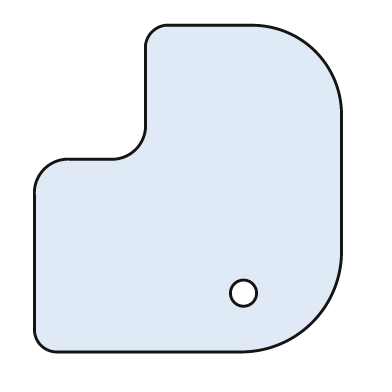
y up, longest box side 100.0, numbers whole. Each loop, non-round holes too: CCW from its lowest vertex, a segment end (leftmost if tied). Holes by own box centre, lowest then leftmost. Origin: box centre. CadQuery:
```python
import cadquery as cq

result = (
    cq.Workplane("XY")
    .moveTo(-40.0, -50.0)
    .lineTo(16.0, -50.0)
    .threePointArc((38.0, -41.0), (47.0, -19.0))
    .lineTo(47.0, 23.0)
    .threePointArc((39.0, 42.0), (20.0, 50.0))
    .lineTo(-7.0, 50.0)
    .threePointArc((-11.0, 48.0), (-13.0, 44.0))
    .lineTo(-13.0, 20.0)
    .threePointArc((-16.0, 12.0), (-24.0, 9.0))
    .lineTo(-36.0, 9.0)
    .threePointArc((-44.0, 6.0), (-47.0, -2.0))
    .lineTo(-47.0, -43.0)
    .threePointArc((-45.0, -48.0), (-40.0, -50.0))
    .close()
    .moveTo(17.0, -32.0)
    .circle(4.0)
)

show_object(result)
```